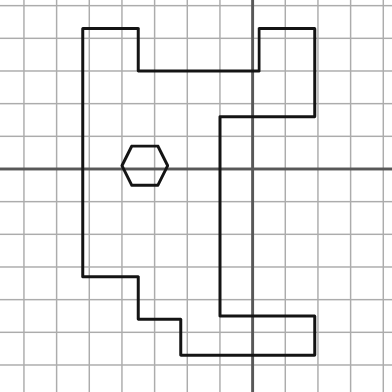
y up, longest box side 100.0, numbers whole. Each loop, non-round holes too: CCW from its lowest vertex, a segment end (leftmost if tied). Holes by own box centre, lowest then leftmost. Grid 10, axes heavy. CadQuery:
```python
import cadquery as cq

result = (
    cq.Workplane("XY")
    .moveTo(-22.0, -57.0)
    .lineTo(19.0, -57.0)
    .lineTo(19.0, -45.0)
    .lineTo(-10.0, -45.0)
    .lineTo(-10.0, 16.0)
    .lineTo(19.0, 16.0)
    .lineTo(19.0, 43.0)
    .lineTo(2.0, 43.0)
    .lineTo(2.0, 30.0)
    .lineTo(-35.0, 30.0)
    .lineTo(-35.0, 43.0)
    .lineTo(-52.0, 43.0)
    .lineTo(-52.0, -33.0)
    .lineTo(-35.0, -33.0)
    .lineTo(-35.0, -46.0)
    .lineTo(-22.0, -46.0)
    .close()
    .moveTo(-37.0, -5.0)
    .lineTo(-29.0, -5.0)
    .lineTo(-26.0, 1.0)
    .lineTo(-29.0, 7.0)
    .lineTo(-37.0, 7.0)
    .lineTo(-40.0, 1.0)
    .close()
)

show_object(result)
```